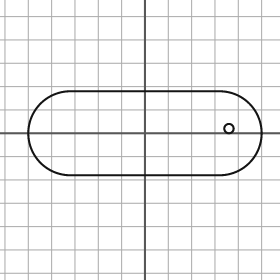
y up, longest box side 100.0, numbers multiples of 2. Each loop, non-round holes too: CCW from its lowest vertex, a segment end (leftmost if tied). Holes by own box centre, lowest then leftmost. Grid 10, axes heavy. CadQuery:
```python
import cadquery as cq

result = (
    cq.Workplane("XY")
    .moveTo(-32.0, -18.0)
    .lineTo(32.0, -18.0)
    .threePointArc((50.0, 0.0), (32.0, 18.0))
    .lineTo(-32.0, 18.0)
    .threePointArc((-50.0, 0.0), (-32.0, -18.0))
    .close()
    .moveTo(36.0, 2.0)
    .circle(2.0)
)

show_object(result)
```